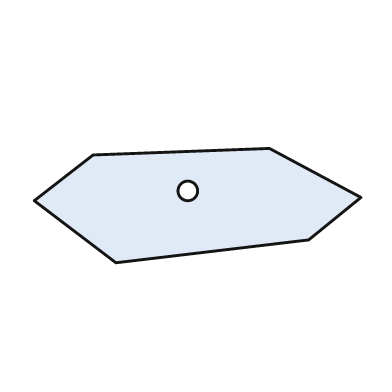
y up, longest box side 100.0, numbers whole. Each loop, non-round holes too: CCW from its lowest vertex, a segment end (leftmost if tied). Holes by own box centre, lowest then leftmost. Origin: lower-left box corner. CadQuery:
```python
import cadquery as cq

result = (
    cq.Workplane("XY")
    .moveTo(25.0, 0.0)
    .lineTo(84.0, 7.0)
    .lineTo(100.0, 20.0)
    .lineTo(72.0, 35.0)
    .lineTo(18.0, 33.0)
    .lineTo(0.0, 19.0)
    .close()
    .moveTo(47.0, 22.0)
    .circle(3.0)
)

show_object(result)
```